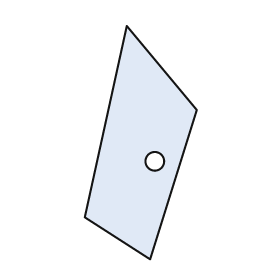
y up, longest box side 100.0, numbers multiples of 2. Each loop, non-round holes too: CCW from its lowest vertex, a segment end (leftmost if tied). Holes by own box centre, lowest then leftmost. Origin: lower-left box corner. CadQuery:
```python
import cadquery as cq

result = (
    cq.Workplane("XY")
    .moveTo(28.0, 0.0)
    .lineTo(48.0, 64.0)
    .lineTo(18.0, 100.0)
    .lineTo(0.0, 18.0)
    .close()
    .moveTo(30.0, 42.0)
    .circle(4.0)
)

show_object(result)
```